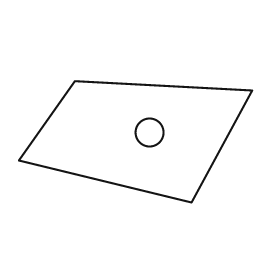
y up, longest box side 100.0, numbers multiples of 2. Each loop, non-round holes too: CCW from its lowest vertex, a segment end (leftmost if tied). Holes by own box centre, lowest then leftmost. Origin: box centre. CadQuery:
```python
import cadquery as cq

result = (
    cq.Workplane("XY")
    .moveTo(24.0, -26.0)
    .lineTo(50.0, 22.0)
    .lineTo(-26.0, 26.0)
    .lineTo(-50.0, -8.0)
    .close()
    .moveTo(6.0, 4.0)
    .circle(6.0)
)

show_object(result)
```